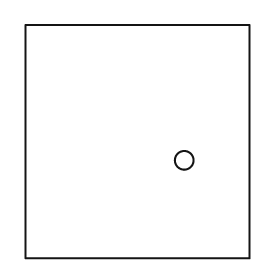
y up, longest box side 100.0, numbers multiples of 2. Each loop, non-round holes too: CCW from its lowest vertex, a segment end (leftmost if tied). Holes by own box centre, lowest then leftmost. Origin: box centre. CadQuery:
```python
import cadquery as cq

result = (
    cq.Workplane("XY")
    .moveTo(-48.0, -50.0)
    .lineTo(48.0, -50.0)
    .lineTo(48.0, 50.0)
    .lineTo(-48.0, 50.0)
    .close()
    .moveTo(20.0, -8.0)
    .circle(4.0)
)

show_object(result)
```